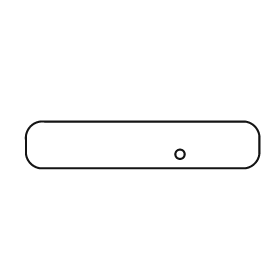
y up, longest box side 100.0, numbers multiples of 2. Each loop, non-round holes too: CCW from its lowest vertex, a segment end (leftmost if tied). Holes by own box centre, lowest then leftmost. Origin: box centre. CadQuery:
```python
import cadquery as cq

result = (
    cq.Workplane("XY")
    .moveTo(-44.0, -10.0)
    .lineTo(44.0, -10.0)
    .threePointArc((48.0, -8.0), (50.0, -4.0))
    .lineTo(50.0, 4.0)
    .threePointArc((48.0, 8.0), (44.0, 10.0))
    .lineTo(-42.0, 10.0)
    .threePointArc((-48.0, 8.0), (-50.0, 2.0))
    .lineTo(-50.0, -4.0)
    .threePointArc((-48.0, -8.0), (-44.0, -10.0))
    .close()
    .moveTo(16.0, -4.0)
    .circle(2.0)
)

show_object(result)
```